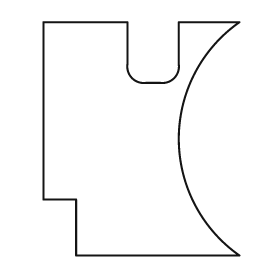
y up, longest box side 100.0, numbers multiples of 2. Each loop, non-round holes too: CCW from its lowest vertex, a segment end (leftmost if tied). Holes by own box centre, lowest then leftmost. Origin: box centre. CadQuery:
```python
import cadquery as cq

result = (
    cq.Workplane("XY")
    .moveTo(-28.0, -50.0)
    .lineTo(42.0, -50.0)
    .threePointArc((16.0, 0.0), (42.0, 50.0))
    .lineTo(16.0, 50.0)
    .lineTo(16.0, 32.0)
    .threePointArc((14.0, 26.0), (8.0, 24.0))
    .lineTo(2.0, 24.0)
    .threePointArc((-4.0, 26.0), (-6.0, 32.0))
    .lineTo(-6.0, 50.0)
    .lineTo(-42.0, 50.0)
    .lineTo(-42.0, -26.0)
    .lineTo(-28.0, -26.0)
    .close()
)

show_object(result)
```